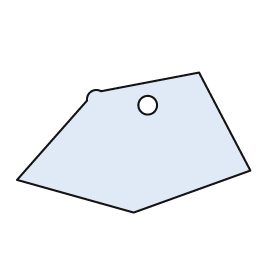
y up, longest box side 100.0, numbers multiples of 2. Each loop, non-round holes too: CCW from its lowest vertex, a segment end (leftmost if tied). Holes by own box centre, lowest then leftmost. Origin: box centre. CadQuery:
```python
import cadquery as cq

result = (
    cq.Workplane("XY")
    .moveTo(0.0, -30.0)
    .lineTo(50.0, -12.0)
    .lineTo(28.0, 30.0)
    .lineTo(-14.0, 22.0)
    .threePointArc((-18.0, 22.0), (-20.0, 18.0))
    .lineTo(-50.0, -16.0)
    .close()
    .moveTo(6.0, 16.0)
    .circle(4.0)
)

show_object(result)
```